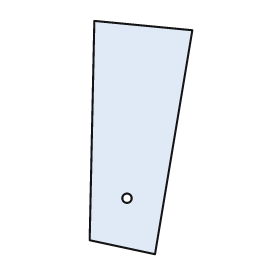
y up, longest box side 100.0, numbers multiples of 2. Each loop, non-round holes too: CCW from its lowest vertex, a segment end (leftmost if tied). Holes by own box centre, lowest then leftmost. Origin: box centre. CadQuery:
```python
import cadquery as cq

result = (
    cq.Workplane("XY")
    .moveTo(6.0, -50.0)
    .lineTo(22.0, 46.0)
    .lineTo(-20.0, 50.0)
    .lineTo(-22.0, -44.0)
    .close()
    .moveTo(-6.0, -26.0)
    .circle(2.0)
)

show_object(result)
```